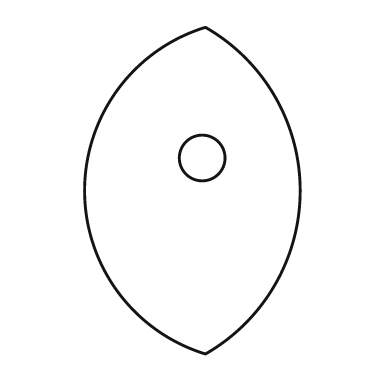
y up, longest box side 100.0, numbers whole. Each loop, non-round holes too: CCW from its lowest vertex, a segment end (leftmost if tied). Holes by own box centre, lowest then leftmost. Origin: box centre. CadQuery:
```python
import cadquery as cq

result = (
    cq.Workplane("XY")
    .moveTo(4.0, -50.0)
    .threePointArc((33.0, 0.0), (4.0, 50.0))
    .threePointArc((-33.0, 0.0), (4.0, -50.0))
    .close()
    .moveTo(3.0, 10.0)
    .circle(7.0)
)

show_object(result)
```